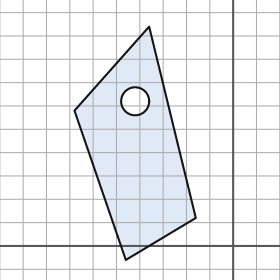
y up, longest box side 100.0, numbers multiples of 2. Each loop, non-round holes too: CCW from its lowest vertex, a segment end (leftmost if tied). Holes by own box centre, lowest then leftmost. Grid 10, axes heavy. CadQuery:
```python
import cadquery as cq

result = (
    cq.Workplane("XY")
    .moveTo(-46.0, -6.0)
    .lineTo(-16.0, 12.0)
    .lineTo(-36.0, 94.0)
    .lineTo(-68.0, 58.0)
    .close()
    .moveTo(-42.0, 62.0)
    .circle(6.0)
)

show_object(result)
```